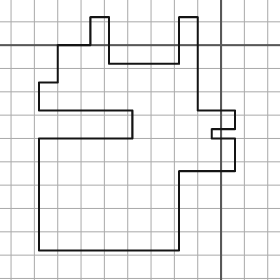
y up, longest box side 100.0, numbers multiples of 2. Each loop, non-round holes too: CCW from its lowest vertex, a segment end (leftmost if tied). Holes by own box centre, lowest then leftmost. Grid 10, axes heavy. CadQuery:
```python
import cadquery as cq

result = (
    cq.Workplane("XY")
    .moveTo(-78.0, -88.0)
    .lineTo(-18.0, -88.0)
    .lineTo(-18.0, -54.0)
    .lineTo(6.0, -54.0)
    .lineTo(6.0, -40.0)
    .lineTo(-4.0, -40.0)
    .lineTo(-4.0, -36.0)
    .lineTo(6.0, -36.0)
    .lineTo(6.0, -28.0)
    .lineTo(-10.0, -28.0)
    .lineTo(-10.0, 12.0)
    .lineTo(-18.0, 12.0)
    .lineTo(-18.0, -8.0)
    .lineTo(-48.0, -8.0)
    .lineTo(-48.0, 12.0)
    .lineTo(-56.0, 12.0)
    .lineTo(-56.0, 0.0)
    .lineTo(-70.0, 0.0)
    .lineTo(-70.0, -16.0)
    .lineTo(-78.0, -16.0)
    .lineTo(-78.0, -28.0)
    .lineTo(-38.0, -28.0)
    .lineTo(-38.0, -40.0)
    .lineTo(-78.0, -40.0)
    .close()
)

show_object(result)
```